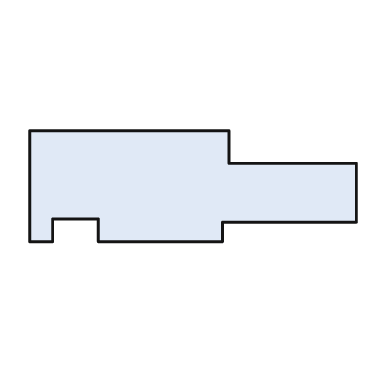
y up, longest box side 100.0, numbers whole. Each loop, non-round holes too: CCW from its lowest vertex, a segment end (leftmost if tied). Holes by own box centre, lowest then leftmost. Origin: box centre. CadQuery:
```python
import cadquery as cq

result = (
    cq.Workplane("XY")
    .moveTo(-50.0, -17.0)
    .lineTo(-43.0, -17.0)
    .lineTo(-43.0, -10.0)
    .lineTo(-29.0, -10.0)
    .lineTo(-29.0, -17.0)
    .lineTo(9.0, -17.0)
    .lineTo(9.0, -11.0)
    .lineTo(50.0, -11.0)
    .lineTo(50.0, 7.0)
    .lineTo(11.0, 7.0)
    .lineTo(11.0, 17.0)
    .lineTo(-50.0, 17.0)
    .close()
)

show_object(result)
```